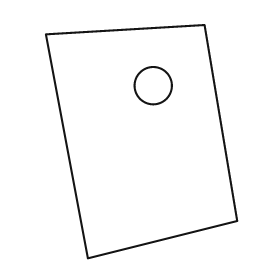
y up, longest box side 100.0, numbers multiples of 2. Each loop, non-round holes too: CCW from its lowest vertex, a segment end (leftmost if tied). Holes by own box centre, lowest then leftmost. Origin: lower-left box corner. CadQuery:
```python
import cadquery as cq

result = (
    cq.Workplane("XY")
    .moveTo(18.0, 0.0)
    .lineTo(82.0, 16.0)
    .lineTo(68.0, 100.0)
    .lineTo(0.0, 96.0)
    .close()
    .moveTo(46.0, 74.0)
    .circle(8.0)
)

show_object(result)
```